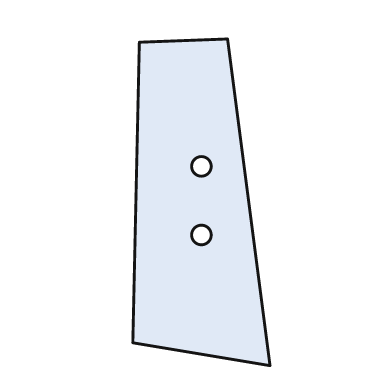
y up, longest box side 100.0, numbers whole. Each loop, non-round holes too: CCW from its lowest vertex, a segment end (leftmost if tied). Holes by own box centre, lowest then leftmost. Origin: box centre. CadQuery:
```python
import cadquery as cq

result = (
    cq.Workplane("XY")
    .moveTo(21.0, -50.0)
    .lineTo(8.0, 50.0)
    .lineTo(-19.0, 49.0)
    .lineTo(-21.0, -43.0)
    .close()
    .moveTo(0.0, -10.0)
    .circle(3.0)
    .moveTo(0.0, 11.0)
    .circle(3.0)
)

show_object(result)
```